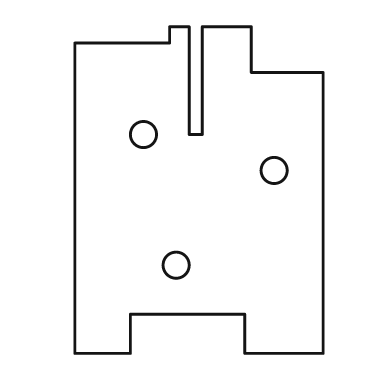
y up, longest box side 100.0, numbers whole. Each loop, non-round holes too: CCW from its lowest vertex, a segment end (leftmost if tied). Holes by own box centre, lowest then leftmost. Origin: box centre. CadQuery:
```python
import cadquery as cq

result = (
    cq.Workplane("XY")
    .moveTo(-38.0, -50.0)
    .lineTo(-21.0, -50.0)
    .lineTo(-21.0, -38.0)
    .lineTo(14.0, -38.0)
    .lineTo(14.0, -50.0)
    .lineTo(38.0, -50.0)
    .lineTo(38.0, 36.0)
    .lineTo(16.0, 36.0)
    .lineTo(16.0, 50.0)
    .lineTo(1.0, 50.0)
    .lineTo(1.0, 17.0)
    .lineTo(-3.0, 17.0)
    .lineTo(-3.0, 50.0)
    .lineTo(-9.0, 50.0)
    .lineTo(-9.0, 45.0)
    .lineTo(-38.0, 45.0)
    .close()
    .moveTo(-7.0, -23.0)
    .circle(4.0)
    .moveTo(23.0, 6.0)
    .circle(4.0)
    .moveTo(-17.0, 17.0)
    .circle(4.0)
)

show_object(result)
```